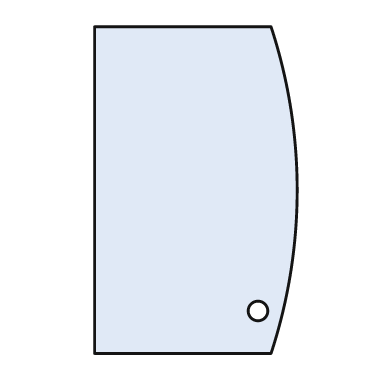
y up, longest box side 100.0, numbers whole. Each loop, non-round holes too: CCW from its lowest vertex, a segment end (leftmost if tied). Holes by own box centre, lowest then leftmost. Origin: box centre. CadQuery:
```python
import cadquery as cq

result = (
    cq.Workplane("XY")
    .moveTo(-31.0, -50.0)
    .lineTo(23.0, -50.0)
    .threePointArc((31.0, 0.0), (23.0, 50.0))
    .lineTo(-31.0, 50.0)
    .close()
    .moveTo(19.0, -37.0)
    .circle(3.0)
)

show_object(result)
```